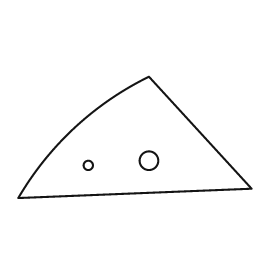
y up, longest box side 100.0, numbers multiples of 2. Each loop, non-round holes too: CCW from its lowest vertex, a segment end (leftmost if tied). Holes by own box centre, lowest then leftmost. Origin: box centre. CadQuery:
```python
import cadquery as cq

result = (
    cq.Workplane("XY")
    .moveTo(-50.0, -26.0)
    .lineTo(50.0, -22.0)
    .lineTo(6.0, 26.0)
    .threePointArc((-26.0, 4.0), (-50.0, -26.0))
    .close()
    .moveTo(-20.0, -12.0)
    .circle(2.0)
    .moveTo(6.0, -10.0)
    .circle(4.0)
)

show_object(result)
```